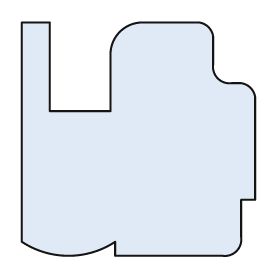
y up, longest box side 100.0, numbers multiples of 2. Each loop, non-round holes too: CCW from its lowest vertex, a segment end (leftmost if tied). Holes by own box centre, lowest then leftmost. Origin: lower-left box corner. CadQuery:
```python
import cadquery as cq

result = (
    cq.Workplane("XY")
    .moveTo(40.0, 0.0)
    .lineTo(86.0, 0.0)
    .threePointArc((92.0, 2.0), (94.0, 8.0))
    .lineTo(94.0, 24.0)
    .lineTo(100.0, 24.0)
    .lineTo(100.0, 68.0)
    .threePointArc((98.0, 72.0), (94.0, 74.0))
    .lineTo(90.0, 74.0)
    .threePointArc((84.0, 76.0), (82.0, 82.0))
    .lineTo(82.0, 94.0)
    .threePointArc((80.0, 98.0), (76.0, 100.0))
    .lineTo(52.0, 100.0)
    .threePointArc((42.0, 96.0), (38.0, 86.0))
    .lineTo(38.0, 62.0)
    .lineTo(12.0, 62.0)
    .lineTo(12.0, 100.0)
    .lineTo(0.0, 100.0)
    .lineTo(0.0, 6.0)
    .threePointArc((20.0, 0.0), (40.0, 6.0))
    .close()
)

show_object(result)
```